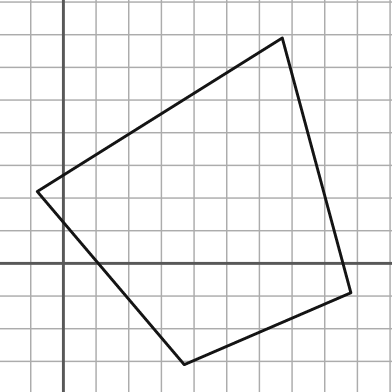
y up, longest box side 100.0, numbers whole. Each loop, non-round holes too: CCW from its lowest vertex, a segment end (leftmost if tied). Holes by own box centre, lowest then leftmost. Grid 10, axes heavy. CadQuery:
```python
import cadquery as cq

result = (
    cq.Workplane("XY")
    .moveTo(37.0, -31.0)
    .lineTo(88.0, -9.0)
    .lineTo(67.0, 69.0)
    .lineTo(-8.0, 22.0)
    .close()
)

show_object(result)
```